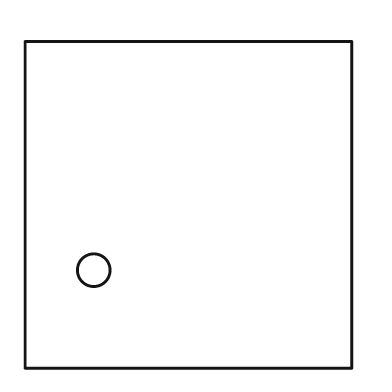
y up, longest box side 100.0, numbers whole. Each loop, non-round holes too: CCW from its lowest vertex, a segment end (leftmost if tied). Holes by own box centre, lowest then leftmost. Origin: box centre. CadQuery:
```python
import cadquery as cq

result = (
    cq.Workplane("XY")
    .moveTo(-50.0, -50.0)
    .lineTo(50.0, -50.0)
    .lineTo(50.0, 50.0)
    .lineTo(-50.0, 50.0)
    .close()
    .moveTo(-29.0, -20.0)
    .circle(5.0)
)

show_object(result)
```